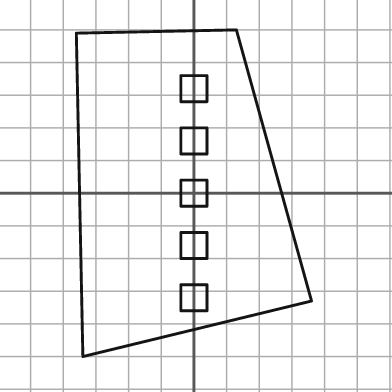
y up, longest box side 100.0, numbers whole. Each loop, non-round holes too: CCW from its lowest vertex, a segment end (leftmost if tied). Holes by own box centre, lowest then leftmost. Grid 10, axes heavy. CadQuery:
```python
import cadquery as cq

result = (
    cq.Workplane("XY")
    .moveTo(-34.0, -50.0)
    .lineTo(36.0, -33.0)
    .lineTo(13.0, 50.0)
    .lineTo(-36.0, 49.0)
    .close()
    .moveTo(-4.0, -36.0)
    .lineTo(4.0, -36.0)
    .lineTo(4.0, -28.0)
    .lineTo(-4.0, -28.0)
    .close()
    .moveTo(-4.0, -20.0)
    .lineTo(4.0, -20.0)
    .lineTo(4.0, -12.0)
    .lineTo(-4.0, -12.0)
    .close()
    .moveTo(-4.0, -4.0)
    .lineTo(4.0, -4.0)
    .lineTo(4.0, 4.0)
    .lineTo(-4.0, 4.0)
    .close()
    .moveTo(-4.0, 12.0)
    .lineTo(4.0, 12.0)
    .lineTo(4.0, 20.0)
    .lineTo(-4.0, 20.0)
    .close()
    .moveTo(-4.0, 28.0)
    .lineTo(4.0, 28.0)
    .lineTo(4.0, 36.0)
    .lineTo(-4.0, 36.0)
    .close()
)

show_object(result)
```